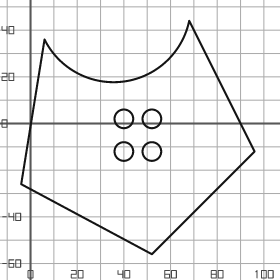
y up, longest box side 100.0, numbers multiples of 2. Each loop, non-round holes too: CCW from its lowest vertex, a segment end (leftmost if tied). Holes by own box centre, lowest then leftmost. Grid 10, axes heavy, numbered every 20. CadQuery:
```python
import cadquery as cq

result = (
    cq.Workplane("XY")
    .moveTo(52.0, -56.0)
    .lineTo(96.0, -12.0)
    .lineTo(68.0, 44.0)
    .threePointArc((40.0, 18.0), (6.0, 36.0))
    .lineTo(-4.0, -26.0)
    .close()
    .moveTo(40.0, -12.0)
    .circle(4.0)
    .moveTo(52.0, -12.0)
    .circle(4.0)
    .moveTo(40.0, 2.0)
    .circle(4.0)
    .moveTo(52.0, 2.0)
    .circle(4.0)
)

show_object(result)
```